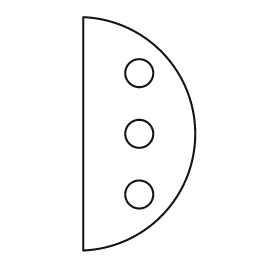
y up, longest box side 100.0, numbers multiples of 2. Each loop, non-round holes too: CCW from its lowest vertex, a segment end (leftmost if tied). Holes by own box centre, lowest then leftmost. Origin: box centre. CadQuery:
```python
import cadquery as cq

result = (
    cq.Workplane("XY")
    .moveTo(-24.0, -50.0)
    .threePointArc((24.0, 0.0), (-24.0, 50.0))
    .close()
    .moveTo(0.0, -26.0)
    .circle(6.0)
    .moveTo(0.0, 0.0)
    .circle(6.0)
    .moveTo(0.0, 26.0)
    .circle(6.0)
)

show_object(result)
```